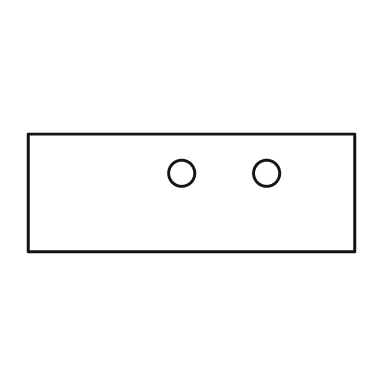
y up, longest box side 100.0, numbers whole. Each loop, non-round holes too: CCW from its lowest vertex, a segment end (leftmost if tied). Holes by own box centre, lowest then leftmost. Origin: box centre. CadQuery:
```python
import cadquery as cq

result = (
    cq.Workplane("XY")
    .moveTo(-50.0, -18.0)
    .lineTo(50.0, -18.0)
    .lineTo(50.0, 18.0)
    .lineTo(-50.0, 18.0)
    .close()
    .moveTo(-3.0, 6.0)
    .circle(4.0)
    .moveTo(23.0, 6.0)
    .circle(4.0)
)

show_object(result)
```